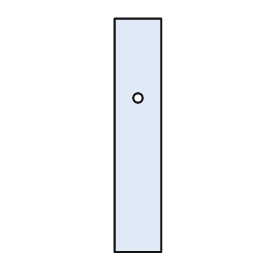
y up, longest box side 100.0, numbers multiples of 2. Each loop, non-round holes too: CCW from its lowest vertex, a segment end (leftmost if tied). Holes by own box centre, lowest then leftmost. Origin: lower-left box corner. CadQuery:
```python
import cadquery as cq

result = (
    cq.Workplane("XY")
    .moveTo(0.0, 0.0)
    .lineTo(20.0, 0.0)
    .lineTo(20.0, 100.0)
    .lineTo(0.0, 100.0)
    .close()
    .moveTo(10.0, 66.0)
    .circle(2.0)
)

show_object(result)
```